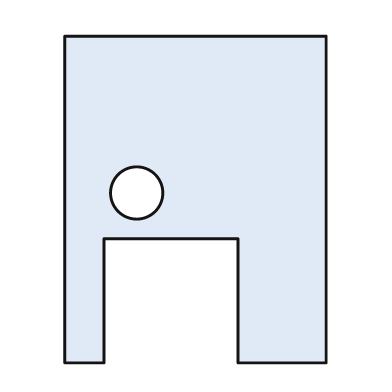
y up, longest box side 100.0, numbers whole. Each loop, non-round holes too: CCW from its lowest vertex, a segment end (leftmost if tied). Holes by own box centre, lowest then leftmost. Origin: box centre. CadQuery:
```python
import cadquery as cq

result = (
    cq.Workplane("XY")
    .moveTo(-40.0, -50.0)
    .lineTo(-28.0, -50.0)
    .lineTo(-28.0, -12.0)
    .lineTo(13.0, -12.0)
    .lineTo(13.0, -50.0)
    .lineTo(40.0, -50.0)
    .lineTo(40.0, 50.0)
    .lineTo(-40.0, 50.0)
    .close()
    .moveTo(-18.0, 2.0)
    .circle(8.0)
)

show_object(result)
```